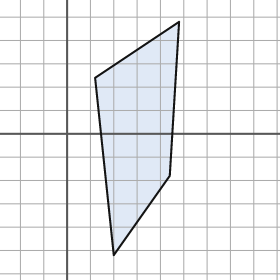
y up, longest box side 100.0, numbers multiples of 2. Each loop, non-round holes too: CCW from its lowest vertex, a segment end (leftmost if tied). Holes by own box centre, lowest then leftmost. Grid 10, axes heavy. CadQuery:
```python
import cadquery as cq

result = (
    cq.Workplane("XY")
    .moveTo(20.0, -52.0)
    .lineTo(44.0, -18.0)
    .lineTo(48.0, 48.0)
    .lineTo(12.0, 24.0)
    .close()
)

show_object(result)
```